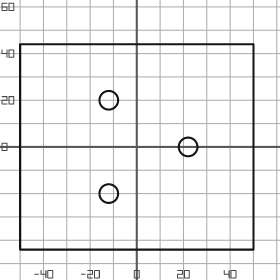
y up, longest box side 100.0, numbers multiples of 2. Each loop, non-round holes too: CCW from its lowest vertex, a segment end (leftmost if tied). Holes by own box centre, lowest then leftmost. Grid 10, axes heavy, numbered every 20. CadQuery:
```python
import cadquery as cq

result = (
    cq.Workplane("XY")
    .moveTo(-50.0, -44.0)
    .lineTo(50.0, -44.0)
    .lineTo(50.0, 44.0)
    .lineTo(-50.0, 44.0)
    .close()
    .moveTo(-12.0, -20.0)
    .circle(4.0)
    .moveTo(22.0, 0.0)
    .circle(4.0)
    .moveTo(-12.0, 20.0)
    .circle(4.0)
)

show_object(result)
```